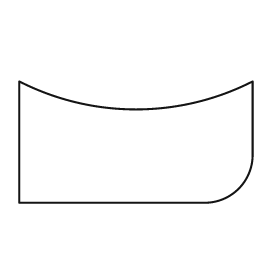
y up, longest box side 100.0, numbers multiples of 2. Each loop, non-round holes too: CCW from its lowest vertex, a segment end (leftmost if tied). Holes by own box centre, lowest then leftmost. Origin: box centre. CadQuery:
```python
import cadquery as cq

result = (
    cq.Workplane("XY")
    .moveTo(-50.0, -26.0)
    .lineTo(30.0, -26.0)
    .threePointArc((44.0, -20.0), (50.0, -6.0))
    .lineTo(50.0, 26.0)
    .threePointArc((0.0, 14.0), (-50.0, 26.0))
    .close()
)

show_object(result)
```